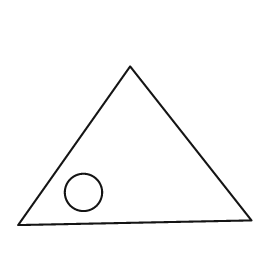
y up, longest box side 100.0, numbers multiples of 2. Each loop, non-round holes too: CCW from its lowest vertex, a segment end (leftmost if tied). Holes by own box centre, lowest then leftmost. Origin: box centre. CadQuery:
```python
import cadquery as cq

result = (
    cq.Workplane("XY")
    .moveTo(-50.0, -34.0)
    .lineTo(50.0, -32.0)
    .lineTo(-2.0, 34.0)
    .close()
    .moveTo(-22.0, -20.0)
    .circle(8.0)
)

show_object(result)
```